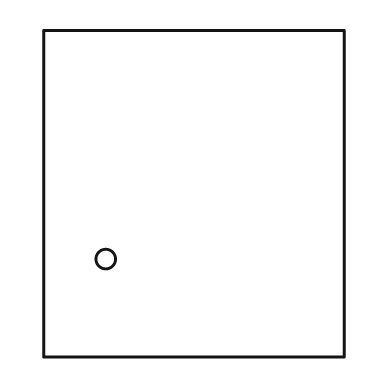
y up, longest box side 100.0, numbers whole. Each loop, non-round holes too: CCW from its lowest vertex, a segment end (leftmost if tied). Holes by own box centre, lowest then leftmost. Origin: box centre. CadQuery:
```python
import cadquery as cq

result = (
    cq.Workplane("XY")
    .moveTo(-46.0, -50.0)
    .lineTo(46.0, -50.0)
    .lineTo(46.0, 50.0)
    .lineTo(-46.0, 50.0)
    .close()
    .moveTo(-27.0, -20.0)
    .circle(3.0)
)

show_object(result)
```